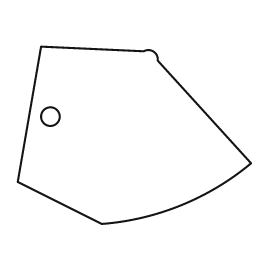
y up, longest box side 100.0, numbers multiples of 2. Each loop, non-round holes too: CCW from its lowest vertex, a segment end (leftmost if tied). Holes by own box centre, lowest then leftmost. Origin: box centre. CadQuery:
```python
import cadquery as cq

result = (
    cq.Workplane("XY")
    .moveTo(-14.0, -38.0)
    .threePointArc((20.0, -30.0), (50.0, -12.0))
    .lineTo(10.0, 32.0)
    .threePointArc((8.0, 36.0), (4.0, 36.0))
    .lineTo(-40.0, 38.0)
    .lineTo(-50.0, -20.0)
    .close()
    .moveTo(-36.0, 8.0)
    .circle(4.0)
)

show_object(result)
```